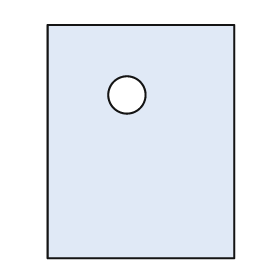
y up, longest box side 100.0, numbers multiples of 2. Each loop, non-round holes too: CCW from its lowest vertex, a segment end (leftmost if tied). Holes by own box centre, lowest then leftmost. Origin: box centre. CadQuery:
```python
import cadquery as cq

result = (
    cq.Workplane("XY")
    .moveTo(-40.0, -50.0)
    .lineTo(40.0, -50.0)
    .lineTo(40.0, 50.0)
    .lineTo(-40.0, 50.0)
    .close()
    .moveTo(-6.0, 20.0)
    .circle(8.0)
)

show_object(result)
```